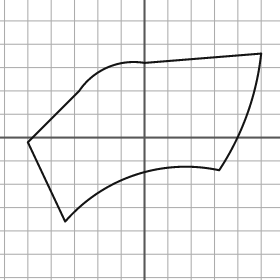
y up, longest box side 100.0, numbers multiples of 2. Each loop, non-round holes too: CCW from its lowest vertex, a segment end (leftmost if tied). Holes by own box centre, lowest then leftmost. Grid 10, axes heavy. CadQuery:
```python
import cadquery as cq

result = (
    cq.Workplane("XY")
    .moveTo(-34.0, -36.0)
    .threePointArc((-4.0, -16.0), (32.0, -14.0))
    .threePointArc((44.0, 10.0), (50.0, 36.0))
    .lineTo(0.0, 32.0)
    .threePointArc((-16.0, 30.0), (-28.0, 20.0))
    .lineTo(-50.0, -2.0)
    .close()
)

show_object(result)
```